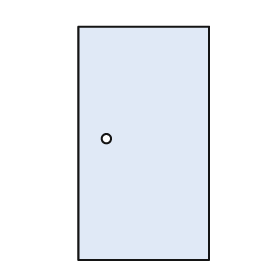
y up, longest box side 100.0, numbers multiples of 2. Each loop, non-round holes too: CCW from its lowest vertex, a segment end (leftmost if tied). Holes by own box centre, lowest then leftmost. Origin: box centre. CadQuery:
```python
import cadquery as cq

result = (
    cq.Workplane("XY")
    .moveTo(-28.0, -50.0)
    .lineTo(28.0, -50.0)
    .lineTo(28.0, 50.0)
    .lineTo(-28.0, 50.0)
    .close()
    .moveTo(-16.0, 2.0)
    .circle(2.0)
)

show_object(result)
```